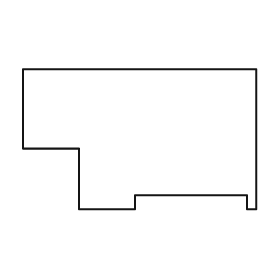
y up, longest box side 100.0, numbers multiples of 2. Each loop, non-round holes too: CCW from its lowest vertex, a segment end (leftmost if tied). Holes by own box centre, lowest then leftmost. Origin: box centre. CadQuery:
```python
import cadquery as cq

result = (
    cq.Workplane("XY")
    .moveTo(-26.0, -30.0)
    .lineTo(-2.0, -30.0)
    .lineTo(-2.0, -24.0)
    .lineTo(46.0, -24.0)
    .lineTo(46.0, -30.0)
    .lineTo(50.0, -30.0)
    .lineTo(50.0, 30.0)
    .lineTo(-50.0, 30.0)
    .lineTo(-50.0, -4.0)
    .lineTo(-26.0, -4.0)
    .close()
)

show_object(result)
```